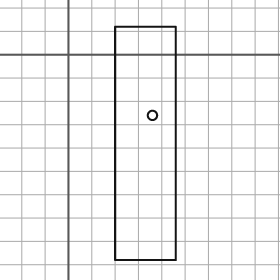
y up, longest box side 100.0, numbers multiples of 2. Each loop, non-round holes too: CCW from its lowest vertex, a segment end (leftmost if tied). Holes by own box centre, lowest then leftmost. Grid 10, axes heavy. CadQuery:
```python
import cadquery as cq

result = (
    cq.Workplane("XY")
    .moveTo(20.0, -88.0)
    .lineTo(46.0, -88.0)
    .lineTo(46.0, 12.0)
    .lineTo(20.0, 12.0)
    .close()
    .moveTo(36.0, -26.0)
    .circle(2.0)
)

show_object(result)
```